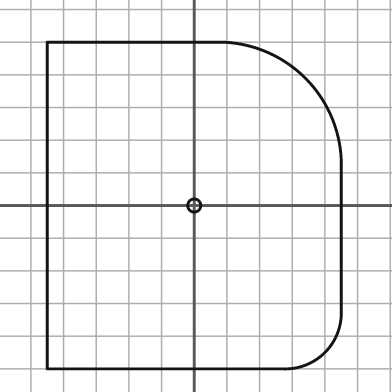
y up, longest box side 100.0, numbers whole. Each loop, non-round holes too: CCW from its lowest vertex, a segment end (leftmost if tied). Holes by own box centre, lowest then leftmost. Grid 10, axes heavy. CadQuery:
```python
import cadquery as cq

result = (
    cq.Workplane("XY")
    .moveTo(-45.0, -50.0)
    .lineTo(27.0, -50.0)
    .threePointArc((40.0, -45.0), (45.0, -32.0))
    .lineTo(45.0, 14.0)
    .threePointArc((34.0, 39.0), (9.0, 50.0))
    .lineTo(-45.0, 50.0)
    .close()
    .moveTo(0.0, 0.0)
    .circle(2.0)
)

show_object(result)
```